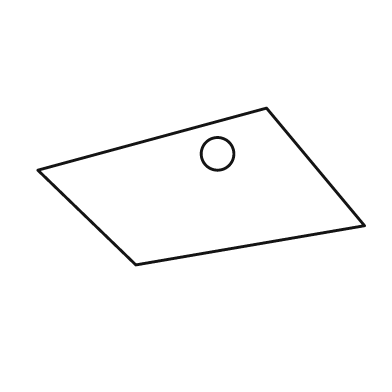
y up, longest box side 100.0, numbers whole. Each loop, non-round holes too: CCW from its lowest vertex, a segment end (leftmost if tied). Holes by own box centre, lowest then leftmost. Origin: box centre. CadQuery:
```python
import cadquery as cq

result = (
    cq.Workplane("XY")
    .moveTo(-20.0, -24.0)
    .lineTo(50.0, -12.0)
    .lineTo(20.0, 24.0)
    .lineTo(-50.0, 5.0)
    .close()
    .moveTo(5.0, 10.0)
    .circle(5.0)
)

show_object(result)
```